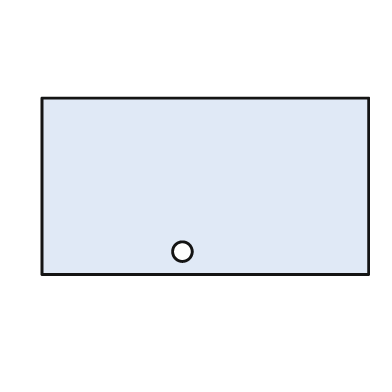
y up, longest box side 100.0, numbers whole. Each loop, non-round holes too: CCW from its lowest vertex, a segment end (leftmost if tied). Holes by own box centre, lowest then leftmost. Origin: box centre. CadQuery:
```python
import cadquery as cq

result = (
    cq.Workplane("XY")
    .moveTo(-50.0, -27.0)
    .lineTo(50.0, -27.0)
    .lineTo(50.0, 27.0)
    .lineTo(-50.0, 27.0)
    .close()
    .moveTo(-7.0, -20.0)
    .circle(3.0)
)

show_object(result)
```